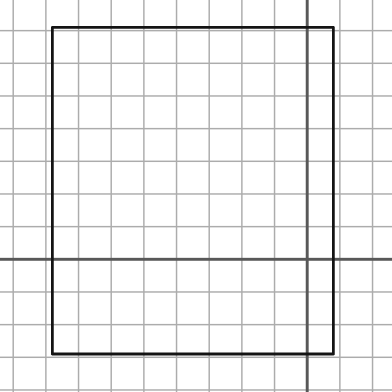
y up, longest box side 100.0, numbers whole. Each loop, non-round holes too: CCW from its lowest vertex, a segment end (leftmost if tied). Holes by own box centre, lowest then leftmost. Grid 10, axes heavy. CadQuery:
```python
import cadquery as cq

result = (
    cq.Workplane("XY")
    .moveTo(-78.0, -29.0)
    .lineTo(8.0, -29.0)
    .lineTo(8.0, 71.0)
    .lineTo(-78.0, 71.0)
    .close()
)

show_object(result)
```